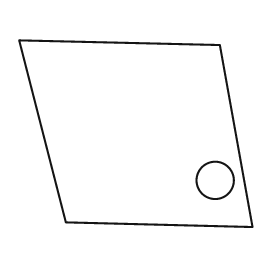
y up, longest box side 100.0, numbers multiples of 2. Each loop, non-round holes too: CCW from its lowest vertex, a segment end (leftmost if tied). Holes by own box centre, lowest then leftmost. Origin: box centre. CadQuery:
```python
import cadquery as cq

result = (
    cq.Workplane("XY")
    .moveTo(50.0, -40.0)
    .lineTo(36.0, 38.0)
    .lineTo(-50.0, 40.0)
    .lineTo(-30.0, -38.0)
    .close()
    .moveTo(34.0, -20.0)
    .circle(8.0)
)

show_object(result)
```